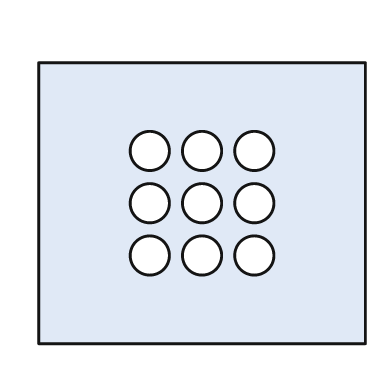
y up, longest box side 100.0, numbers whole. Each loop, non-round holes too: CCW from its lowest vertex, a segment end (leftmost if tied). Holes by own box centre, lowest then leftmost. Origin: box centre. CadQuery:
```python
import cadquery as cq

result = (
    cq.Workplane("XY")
    .moveTo(-50.0, -43.0)
    .lineTo(50.0, -43.0)
    .lineTo(50.0, 43.0)
    .lineTo(-50.0, 43.0)
    .close()
    .moveTo(-16.0, -16.0)
    .circle(6.0)
    .moveTo(0.0, -16.0)
    .circle(6.0)
    .moveTo(16.0, -16.0)
    .circle(6.0)
    .moveTo(-16.0, 0.0)
    .circle(6.0)
    .moveTo(0.0, 0.0)
    .circle(6.0)
    .moveTo(16.0, 0.0)
    .circle(6.0)
    .moveTo(-16.0, 16.0)
    .circle(6.0)
    .moveTo(0.0, 16.0)
    .circle(6.0)
    .moveTo(16.0, 16.0)
    .circle(6.0)
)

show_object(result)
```